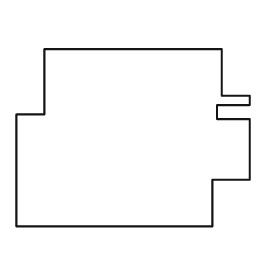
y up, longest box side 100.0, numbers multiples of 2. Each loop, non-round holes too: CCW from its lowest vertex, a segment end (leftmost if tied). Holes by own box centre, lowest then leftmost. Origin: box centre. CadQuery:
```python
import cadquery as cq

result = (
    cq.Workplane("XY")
    .moveTo(-50.0, -38.0)
    .lineTo(34.0, -38.0)
    .lineTo(34.0, -18.0)
    .lineTo(50.0, -18.0)
    .lineTo(50.0, 8.0)
    .lineTo(36.0, 8.0)
    .lineTo(36.0, 14.0)
    .lineTo(50.0, 14.0)
    .lineTo(50.0, 18.0)
    .lineTo(38.0, 18.0)
    .lineTo(38.0, 38.0)
    .lineTo(-38.0, 38.0)
    .lineTo(-38.0, 10.0)
    .lineTo(-50.0, 10.0)
    .close()
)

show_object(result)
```